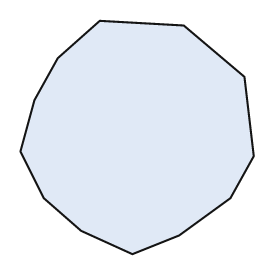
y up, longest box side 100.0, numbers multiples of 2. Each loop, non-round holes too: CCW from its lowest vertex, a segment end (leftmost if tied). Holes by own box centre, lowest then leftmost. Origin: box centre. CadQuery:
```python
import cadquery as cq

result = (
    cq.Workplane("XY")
    .moveTo(-2.0, -50.0)
    .lineTo(18.0, -42.0)
    .lineTo(40.0, -26.0)
    .lineTo(50.0, -8.0)
    .lineTo(46.0, 26.0)
    .lineTo(20.0, 48.0)
    .lineTo(-16.0, 50.0)
    .lineTo(-34.0, 34.0)
    .lineTo(-44.0, 16.0)
    .lineTo(-50.0, -6.0)
    .lineTo(-40.0, -26.0)
    .lineTo(-24.0, -40.0)
    .close()
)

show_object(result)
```